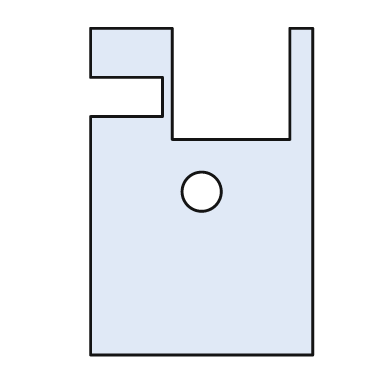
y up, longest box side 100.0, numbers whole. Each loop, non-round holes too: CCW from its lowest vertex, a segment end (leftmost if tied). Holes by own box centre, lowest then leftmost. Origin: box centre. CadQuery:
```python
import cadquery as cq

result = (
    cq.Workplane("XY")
    .moveTo(-34.0, -50.0)
    .lineTo(34.0, -50.0)
    .lineTo(34.0, 50.0)
    .lineTo(27.0, 50.0)
    .lineTo(27.0, 16.0)
    .lineTo(-9.0, 16.0)
    .lineTo(-9.0, 50.0)
    .lineTo(-34.0, 50.0)
    .lineTo(-34.0, 35.0)
    .lineTo(-12.0, 35.0)
    .lineTo(-12.0, 23.0)
    .lineTo(-34.0, 23.0)
    .close()
    .moveTo(0.0, 0.0)
    .circle(6.0)
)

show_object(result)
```